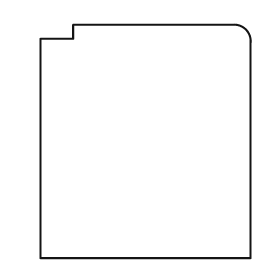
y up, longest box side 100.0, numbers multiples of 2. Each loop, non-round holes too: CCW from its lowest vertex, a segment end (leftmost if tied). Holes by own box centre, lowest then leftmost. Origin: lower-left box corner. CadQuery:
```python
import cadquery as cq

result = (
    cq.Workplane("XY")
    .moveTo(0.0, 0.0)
    .lineTo(90.0, 0.0)
    .lineTo(90.0, 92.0)
    .threePointArc((88.0, 98.0), (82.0, 100.0))
    .lineTo(14.0, 100.0)
    .lineTo(14.0, 94.0)
    .lineTo(0.0, 94.0)
    .close()
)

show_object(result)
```